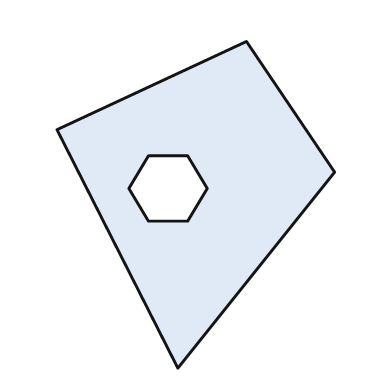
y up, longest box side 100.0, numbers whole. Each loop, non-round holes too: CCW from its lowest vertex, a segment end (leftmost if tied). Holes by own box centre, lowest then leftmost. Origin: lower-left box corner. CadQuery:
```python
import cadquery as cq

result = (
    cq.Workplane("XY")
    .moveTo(37.0, 0.0)
    .lineTo(85.0, 60.0)
    .lineTo(58.0, 100.0)
    .lineTo(0.0, 73.0)
    .close()
    .moveTo(28.0, 45.0)
    .lineTo(40.0, 45.0)
    .lineTo(46.0, 55.0)
    .lineTo(40.0, 65.0)
    .lineTo(28.0, 65.0)
    .lineTo(22.0, 55.0)
    .close()
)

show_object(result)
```